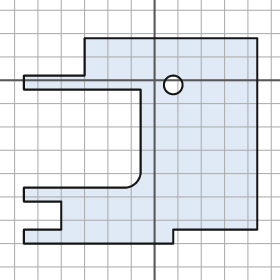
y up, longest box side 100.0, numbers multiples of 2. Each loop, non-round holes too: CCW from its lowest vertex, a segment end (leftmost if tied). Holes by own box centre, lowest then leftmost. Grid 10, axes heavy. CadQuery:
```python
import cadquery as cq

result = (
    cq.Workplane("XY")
    .moveTo(-56.0, -70.0)
    .lineTo(8.0, -70.0)
    .lineTo(8.0, -64.0)
    .lineTo(44.0, -64.0)
    .lineTo(44.0, 18.0)
    .lineTo(-30.0, 18.0)
    .lineTo(-30.0, 2.0)
    .lineTo(-56.0, 2.0)
    .lineTo(-56.0, -4.0)
    .lineTo(-6.0, -4.0)
    .lineTo(-6.0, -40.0)
    .threePointArc((-8.0, -44.0), (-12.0, -46.0))
    .lineTo(-56.0, -46.0)
    .lineTo(-56.0, -52.0)
    .lineTo(-40.0, -52.0)
    .lineTo(-40.0, -64.0)
    .lineTo(-56.0, -64.0)
    .close()
    .moveTo(8.0, -2.0)
    .circle(4.0)
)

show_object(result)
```